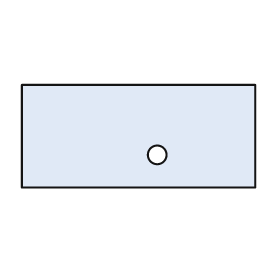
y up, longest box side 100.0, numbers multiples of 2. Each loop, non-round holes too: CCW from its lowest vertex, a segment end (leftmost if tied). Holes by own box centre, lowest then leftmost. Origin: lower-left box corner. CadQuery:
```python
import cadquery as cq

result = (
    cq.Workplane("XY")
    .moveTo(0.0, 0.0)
    .lineTo(100.0, 0.0)
    .lineTo(100.0, 44.0)
    .lineTo(0.0, 44.0)
    .close()
    .moveTo(58.0, 14.0)
    .circle(4.0)
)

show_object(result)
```